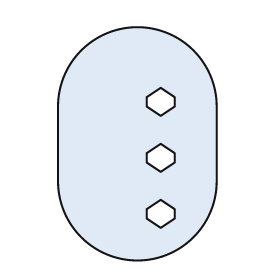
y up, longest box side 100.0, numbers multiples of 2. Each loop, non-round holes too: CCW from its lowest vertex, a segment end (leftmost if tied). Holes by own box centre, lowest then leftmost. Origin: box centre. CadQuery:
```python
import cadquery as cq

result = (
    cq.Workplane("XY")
    .moveTo(-34.0, -16.0)
    .threePointArc((0.0, -50.0), (34.0, -16.0))
    .lineTo(34.0, 16.0)
    .threePointArc((0.0, 50.0), (-34.0, 16.0))
    .close()
    .moveTo(10.0, -36.0)
    .lineTo(16.0, -32.0)
    .lineTo(16.0, -28.0)
    .lineTo(10.0, -24.0)
    .lineTo(4.0, -28.0)
    .lineTo(4.0, -32.0)
    .close()
    .moveTo(10.0, -12.0)
    .lineTo(16.0, -8.0)
    .lineTo(16.0, -4.0)
    .lineTo(10.0, 0.0)
    .lineTo(4.0, -4.0)
    .lineTo(4.0, -8.0)
    .close()
    .moveTo(10.0, 12.0)
    .lineTo(16.0, 16.0)
    .lineTo(16.0, 20.0)
    .lineTo(10.0, 24.0)
    .lineTo(4.0, 20.0)
    .lineTo(4.0, 16.0)
    .close()
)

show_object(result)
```